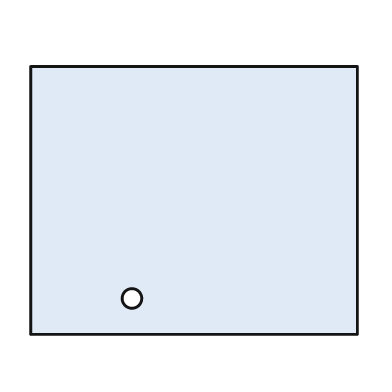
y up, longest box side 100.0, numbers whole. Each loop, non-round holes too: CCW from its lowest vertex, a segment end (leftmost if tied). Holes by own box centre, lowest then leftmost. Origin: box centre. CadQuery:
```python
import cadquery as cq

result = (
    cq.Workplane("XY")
    .moveTo(-50.0, -41.0)
    .lineTo(50.0, -41.0)
    .lineTo(50.0, 41.0)
    .lineTo(-50.0, 41.0)
    .close()
    .moveTo(-19.0, -30.0)
    .circle(3.0)
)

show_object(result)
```